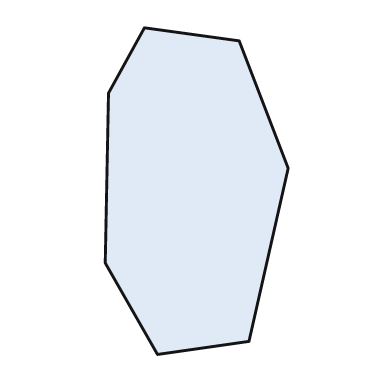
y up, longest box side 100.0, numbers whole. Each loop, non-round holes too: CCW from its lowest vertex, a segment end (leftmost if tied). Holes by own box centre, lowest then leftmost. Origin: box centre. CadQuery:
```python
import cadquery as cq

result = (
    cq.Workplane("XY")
    .moveTo(-12.0, -50.0)
    .lineTo(16.0, -46.0)
    .lineTo(28.0, 7.0)
    .lineTo(13.0, 46.0)
    .lineTo(-16.0, 50.0)
    .lineTo(-27.0, 30.0)
    .lineTo(-28.0, -22.0)
    .close()
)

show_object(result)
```